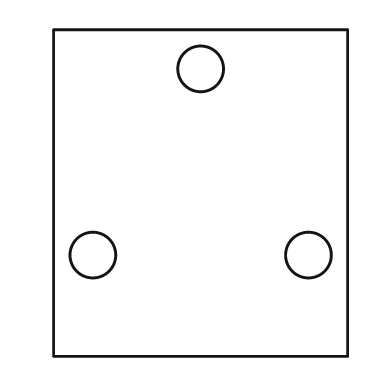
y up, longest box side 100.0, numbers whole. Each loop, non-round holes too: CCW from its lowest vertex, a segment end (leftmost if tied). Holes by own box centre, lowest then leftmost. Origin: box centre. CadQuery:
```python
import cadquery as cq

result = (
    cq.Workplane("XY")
    .moveTo(-45.0, -50.0)
    .lineTo(45.0, -50.0)
    .lineTo(45.0, 50.0)
    .lineTo(-45.0, 50.0)
    .close()
    .moveTo(-33.0, -19.0)
    .circle(7.0)
    .moveTo(33.0, -19.0)
    .circle(7.0)
    .moveTo(0.0, 38.0)
    .circle(7.0)
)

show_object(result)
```